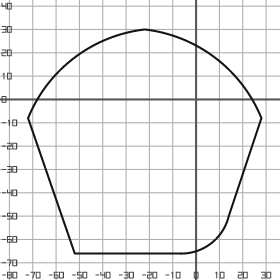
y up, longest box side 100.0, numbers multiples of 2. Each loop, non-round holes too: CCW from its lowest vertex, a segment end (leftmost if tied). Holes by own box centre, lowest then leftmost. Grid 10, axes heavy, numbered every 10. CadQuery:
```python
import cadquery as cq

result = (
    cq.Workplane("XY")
    .moveTo(-52.0, -66.0)
    .lineTo(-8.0, -66.0)
    .threePointArc((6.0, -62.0), (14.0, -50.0))
    .lineTo(28.0, -8.0)
    .threePointArc((8.0, 18.0), (-22.0, 30.0))
    .threePointArc((-52.0, 18.0), (-72.0, -8.0))
    .close()
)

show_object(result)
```